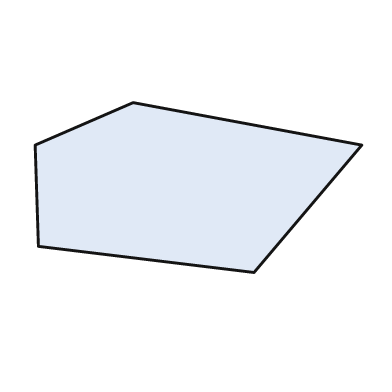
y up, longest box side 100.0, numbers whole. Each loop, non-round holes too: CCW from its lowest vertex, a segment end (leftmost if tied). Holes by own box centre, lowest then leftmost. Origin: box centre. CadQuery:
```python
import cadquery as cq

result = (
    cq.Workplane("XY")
    .moveTo(17.0, -26.0)
    .lineTo(50.0, 13.0)
    .lineTo(-20.0, 26.0)
    .lineTo(-50.0, 13.0)
    .lineTo(-49.0, -18.0)
    .close()
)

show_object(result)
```